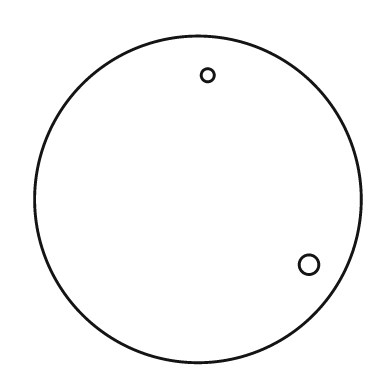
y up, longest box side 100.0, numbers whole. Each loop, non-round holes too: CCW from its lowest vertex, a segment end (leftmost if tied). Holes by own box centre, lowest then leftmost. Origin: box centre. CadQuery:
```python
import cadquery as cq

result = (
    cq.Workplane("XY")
    .moveTo(0.0, 0.0)
    .circle(50.0)
    .moveTo(34.0, -20.0)
    .circle(3.0)
    .moveTo(3.0, 38.0)
    .circle(2.0)
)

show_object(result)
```